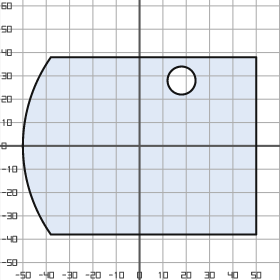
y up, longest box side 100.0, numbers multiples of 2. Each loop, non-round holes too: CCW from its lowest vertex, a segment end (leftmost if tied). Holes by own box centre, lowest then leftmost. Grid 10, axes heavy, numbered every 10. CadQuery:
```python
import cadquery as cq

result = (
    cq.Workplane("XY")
    .moveTo(-38.0, -38.0)
    .lineTo(50.0, -38.0)
    .lineTo(50.0, 38.0)
    .lineTo(-38.0, 38.0)
    .threePointArc((-50.0, 0.0), (-38.0, -38.0))
    .close()
    .moveTo(18.0, 28.0)
    .circle(6.0)
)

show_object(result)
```